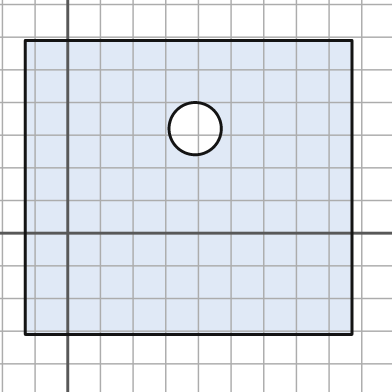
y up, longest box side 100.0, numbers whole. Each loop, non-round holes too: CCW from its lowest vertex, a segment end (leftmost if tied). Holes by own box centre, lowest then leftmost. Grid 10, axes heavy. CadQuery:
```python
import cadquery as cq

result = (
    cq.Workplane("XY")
    .moveTo(-13.0, -31.0)
    .lineTo(87.0, -31.0)
    .lineTo(87.0, 59.0)
    .lineTo(-13.0, 59.0)
    .close()
    .moveTo(39.0, 32.0)
    .circle(8.0)
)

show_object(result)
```